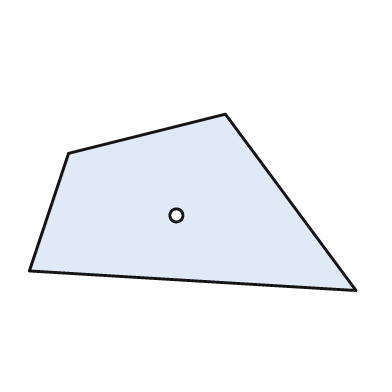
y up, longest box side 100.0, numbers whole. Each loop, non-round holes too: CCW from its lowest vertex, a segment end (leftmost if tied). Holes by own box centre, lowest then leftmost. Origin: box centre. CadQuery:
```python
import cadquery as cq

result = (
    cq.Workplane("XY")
    .moveTo(50.0, -27.0)
    .lineTo(10.0, 27.0)
    .lineTo(-38.0, 15.0)
    .lineTo(-50.0, -21.0)
    .close()
    .moveTo(-5.0, -4.0)
    .circle(2.0)
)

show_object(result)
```